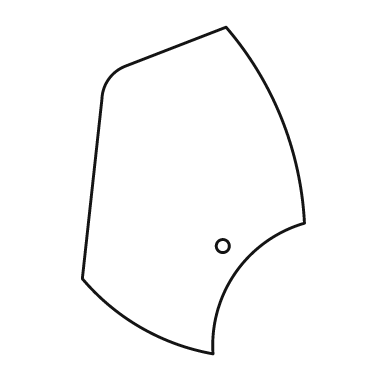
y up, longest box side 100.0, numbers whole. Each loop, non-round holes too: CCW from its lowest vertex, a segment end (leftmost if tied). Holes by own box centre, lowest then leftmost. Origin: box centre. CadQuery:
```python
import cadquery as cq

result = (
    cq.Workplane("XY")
    .moveTo(6.0, -50.0)
    .threePointArc((13.0, -25.0), (34.0, -10.0))
    .threePointArc((27.0, 22.0), (10.0, 50.0))
    .lineTo(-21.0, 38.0)
    .threePointArc((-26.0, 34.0), (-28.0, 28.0))
    .lineTo(-34.0, -27.0)
    .threePointArc((-16.0, -42.0), (6.0, -50.0))
    .close()
    .moveTo(9.0, -17.0)
    .circle(2.0)
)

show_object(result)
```